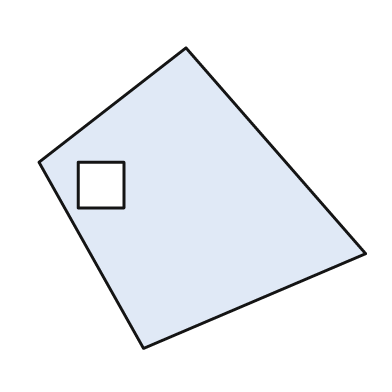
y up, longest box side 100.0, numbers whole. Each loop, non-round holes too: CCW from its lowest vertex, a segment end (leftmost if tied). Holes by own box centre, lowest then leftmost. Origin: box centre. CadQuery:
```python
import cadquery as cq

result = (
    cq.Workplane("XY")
    .moveTo(-18.0, -46.0)
    .lineTo(50.0, -17.0)
    .lineTo(-5.0, 46.0)
    .lineTo(-50.0, 11.0)
    .close()
    .moveTo(-38.0, -3.0)
    .lineTo(-24.0, -3.0)
    .lineTo(-24.0, 11.0)
    .lineTo(-38.0, 11.0)
    .close()
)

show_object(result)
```